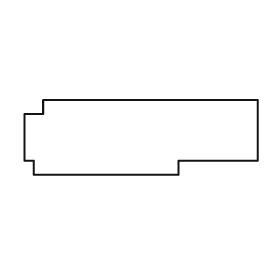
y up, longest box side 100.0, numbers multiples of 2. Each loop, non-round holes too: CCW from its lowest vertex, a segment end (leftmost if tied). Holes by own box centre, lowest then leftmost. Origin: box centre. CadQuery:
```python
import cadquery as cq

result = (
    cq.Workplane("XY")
    .moveTo(-46.0, -16.0)
    .lineTo(16.0, -16.0)
    .lineTo(16.0, -10.0)
    .lineTo(50.0, -10.0)
    .lineTo(50.0, 16.0)
    .lineTo(-42.0, 16.0)
    .lineTo(-42.0, 10.0)
    .lineTo(-50.0, 10.0)
    .lineTo(-50.0, -10.0)
    .lineTo(-46.0, -10.0)
    .close()
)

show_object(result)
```